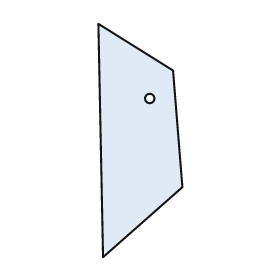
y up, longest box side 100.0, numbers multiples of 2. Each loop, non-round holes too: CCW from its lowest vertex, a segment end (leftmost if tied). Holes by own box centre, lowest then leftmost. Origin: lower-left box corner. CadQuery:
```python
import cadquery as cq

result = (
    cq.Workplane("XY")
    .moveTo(2.0, 0.0)
    .lineTo(36.0, 30.0)
    .lineTo(32.0, 80.0)
    .lineTo(0.0, 100.0)
    .close()
    .moveTo(22.0, 68.0)
    .circle(2.0)
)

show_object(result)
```